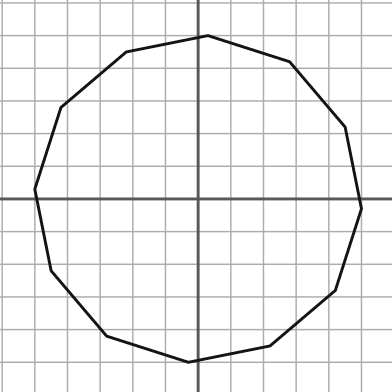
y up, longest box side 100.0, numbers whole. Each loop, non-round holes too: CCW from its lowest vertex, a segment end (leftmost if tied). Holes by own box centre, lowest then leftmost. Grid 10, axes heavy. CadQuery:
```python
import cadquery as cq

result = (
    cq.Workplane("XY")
    .moveTo(-3.0, -50.0)
    .lineTo(22.0, -45.0)
    .lineTo(42.0, -28.0)
    .lineTo(50.0, -3.0)
    .lineTo(45.0, 22.0)
    .lineTo(28.0, 42.0)
    .lineTo(3.0, 50.0)
    .lineTo(-22.0, 45.0)
    .lineTo(-42.0, 28.0)
    .lineTo(-50.0, 3.0)
    .lineTo(-45.0, -22.0)
    .lineTo(-28.0, -42.0)
    .close()
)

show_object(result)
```